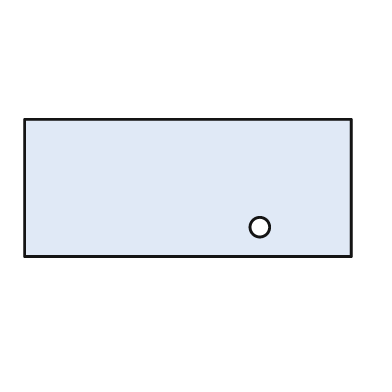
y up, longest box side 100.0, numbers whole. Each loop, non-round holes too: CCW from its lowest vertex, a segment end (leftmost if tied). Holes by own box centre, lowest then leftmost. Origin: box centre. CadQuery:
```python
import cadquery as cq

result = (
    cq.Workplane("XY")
    .moveTo(-50.0, -21.0)
    .lineTo(50.0, -21.0)
    .lineTo(50.0, 21.0)
    .lineTo(-50.0, 21.0)
    .close()
    .moveTo(22.0, -12.0)
    .circle(3.0)
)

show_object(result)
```